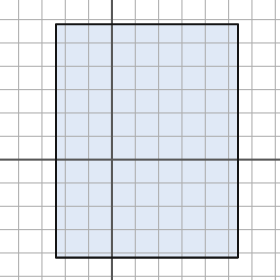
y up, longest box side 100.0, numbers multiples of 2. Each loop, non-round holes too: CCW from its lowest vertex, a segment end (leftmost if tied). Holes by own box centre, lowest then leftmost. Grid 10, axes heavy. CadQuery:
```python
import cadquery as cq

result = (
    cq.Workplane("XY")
    .moveTo(-24.0, -42.0)
    .lineTo(54.0, -42.0)
    .lineTo(54.0, 58.0)
    .lineTo(-24.0, 58.0)
    .close()
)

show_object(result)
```